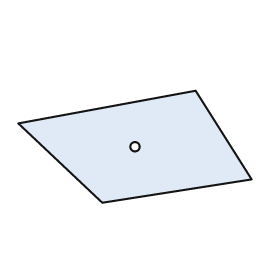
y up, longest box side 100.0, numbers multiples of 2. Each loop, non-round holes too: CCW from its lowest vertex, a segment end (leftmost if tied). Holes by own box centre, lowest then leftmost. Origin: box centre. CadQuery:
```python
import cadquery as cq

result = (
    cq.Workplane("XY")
    .moveTo(-14.0, -24.0)
    .lineTo(50.0, -14.0)
    .lineTo(26.0, 24.0)
    .lineTo(-50.0, 10.0)
    .close()
    .moveTo(0.0, 0.0)
    .circle(2.0)
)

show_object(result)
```